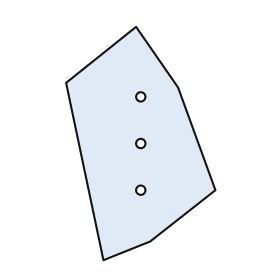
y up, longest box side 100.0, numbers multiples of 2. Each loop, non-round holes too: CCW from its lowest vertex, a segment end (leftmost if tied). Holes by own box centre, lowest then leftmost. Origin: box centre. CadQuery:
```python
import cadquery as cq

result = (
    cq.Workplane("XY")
    .moveTo(-16.0, -50.0)
    .lineTo(4.0, -42.0)
    .lineTo(32.0, -20.0)
    .lineTo(16.0, 24.0)
    .lineTo(-2.0, 50.0)
    .lineTo(-32.0, 26.0)
    .close()
    .moveTo(0.0, -20.0)
    .circle(2.0)
    .moveTo(0.0, 0.0)
    .circle(2.0)
    .moveTo(0.0, 20.0)
    .circle(2.0)
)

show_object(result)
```